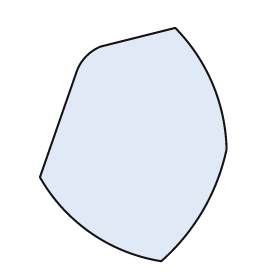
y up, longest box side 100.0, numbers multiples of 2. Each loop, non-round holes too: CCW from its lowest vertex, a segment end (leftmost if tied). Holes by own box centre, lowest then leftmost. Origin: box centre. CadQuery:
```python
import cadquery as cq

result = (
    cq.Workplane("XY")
    .moveTo(12.0, -50.0)
    .threePointArc((30.0, -28.0), (40.0, -2.0))
    .threePointArc((34.0, 26.0), (18.0, 50.0))
    .lineTo(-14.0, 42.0)
    .threePointArc((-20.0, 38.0), (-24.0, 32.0))
    .lineTo(-40.0, -14.0)
    .threePointArc((-18.0, -38.0), (12.0, -50.0))
    .close()
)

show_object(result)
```